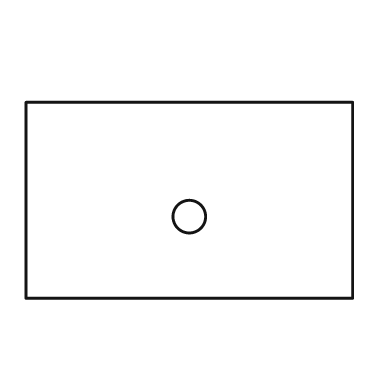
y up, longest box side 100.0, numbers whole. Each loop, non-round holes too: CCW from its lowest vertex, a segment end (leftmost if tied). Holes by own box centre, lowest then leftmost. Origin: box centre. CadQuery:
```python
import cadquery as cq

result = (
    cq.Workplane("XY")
    .moveTo(-50.0, -30.0)
    .lineTo(50.0, -30.0)
    .lineTo(50.0, 30.0)
    .lineTo(-50.0, 30.0)
    .close()
    .moveTo(0.0, -5.0)
    .circle(5.0)
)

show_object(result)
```